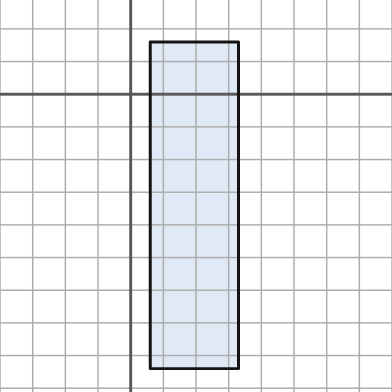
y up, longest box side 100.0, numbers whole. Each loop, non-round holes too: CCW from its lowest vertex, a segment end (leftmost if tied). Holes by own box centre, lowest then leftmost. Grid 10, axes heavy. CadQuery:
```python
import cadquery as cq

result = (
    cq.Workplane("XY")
    .moveTo(6.0, -84.0)
    .lineTo(33.0, -84.0)
    .lineTo(33.0, 16.0)
    .lineTo(6.0, 16.0)
    .close()
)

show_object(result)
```